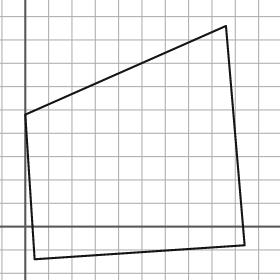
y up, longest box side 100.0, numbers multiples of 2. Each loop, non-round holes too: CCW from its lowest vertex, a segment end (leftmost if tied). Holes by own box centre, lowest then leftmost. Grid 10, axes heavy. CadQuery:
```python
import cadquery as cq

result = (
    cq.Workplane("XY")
    .moveTo(4.0, -14.0)
    .lineTo(94.0, -8.0)
    .lineTo(86.0, 86.0)
    .lineTo(0.0, 48.0)
    .close()
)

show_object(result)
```